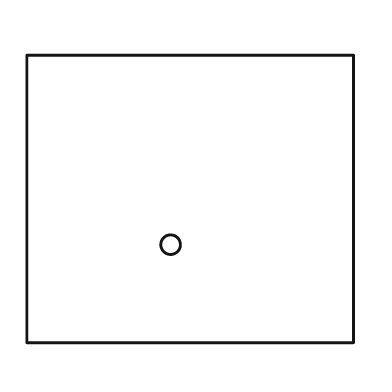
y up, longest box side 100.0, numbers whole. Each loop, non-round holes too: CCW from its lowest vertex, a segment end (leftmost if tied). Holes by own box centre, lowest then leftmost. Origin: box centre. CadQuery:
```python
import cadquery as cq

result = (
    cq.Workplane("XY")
    .moveTo(-50.0, -44.0)
    .lineTo(50.0, -44.0)
    .lineTo(50.0, 44.0)
    .lineTo(-50.0, 44.0)
    .close()
    .moveTo(-6.0, -14.0)
    .circle(3.0)
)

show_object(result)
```